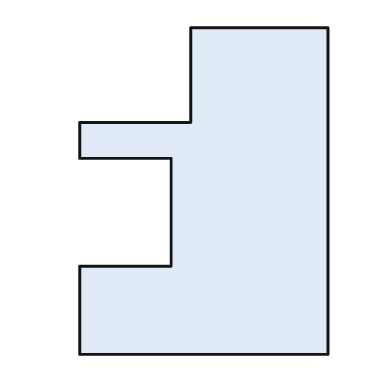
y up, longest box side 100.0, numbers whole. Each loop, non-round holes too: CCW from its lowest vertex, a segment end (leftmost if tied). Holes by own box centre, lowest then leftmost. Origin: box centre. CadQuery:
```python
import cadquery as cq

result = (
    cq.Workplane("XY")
    .moveTo(-38.0, -50.0)
    .lineTo(38.0, -50.0)
    .lineTo(38.0, 50.0)
    .lineTo(-4.0, 50.0)
    .lineTo(-4.0, 21.0)
    .lineTo(-38.0, 21.0)
    .lineTo(-38.0, 10.0)
    .lineTo(-10.0, 10.0)
    .lineTo(-10.0, -23.0)
    .lineTo(-38.0, -23.0)
    .close()
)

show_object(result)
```